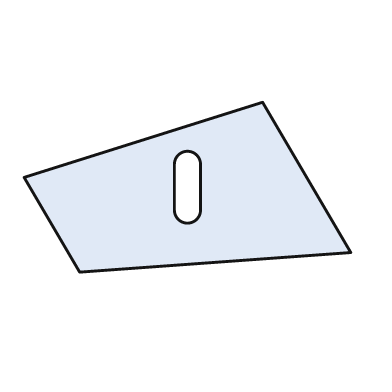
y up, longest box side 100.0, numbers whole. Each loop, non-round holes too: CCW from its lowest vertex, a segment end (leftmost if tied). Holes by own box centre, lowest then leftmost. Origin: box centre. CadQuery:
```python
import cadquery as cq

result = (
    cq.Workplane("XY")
    .moveTo(-33.0, -26.0)
    .lineTo(50.0, -20.0)
    .lineTo(23.0, 26.0)
    .lineTo(-50.0, 3.0)
    .close()
    .moveTo(-4.0, -7.0)
    .threePointArc((0.0, -11.0), (4.0, -7.0))
    .lineTo(4.0, 7.0)
    .threePointArc((0.0, 11.0), (-4.0, 7.0))
    .close()
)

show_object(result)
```